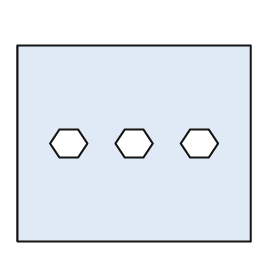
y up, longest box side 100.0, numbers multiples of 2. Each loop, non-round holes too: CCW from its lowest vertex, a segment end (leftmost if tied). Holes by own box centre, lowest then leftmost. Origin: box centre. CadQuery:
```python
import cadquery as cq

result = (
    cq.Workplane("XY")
    .moveTo(-50.0, -42.0)
    .lineTo(50.0, -42.0)
    .lineTo(50.0, 42.0)
    .lineTo(-50.0, 42.0)
    .close()
    .moveTo(-32.0, -6.0)
    .lineTo(-24.0, -6.0)
    .lineTo(-20.0, 0.0)
    .lineTo(-24.0, 6.0)
    .lineTo(-32.0, 6.0)
    .lineTo(-36.0, 0.0)
    .close()
    .moveTo(-4.0, -6.0)
    .lineTo(4.0, -6.0)
    .lineTo(8.0, 0.0)
    .lineTo(4.0, 6.0)
    .lineTo(-4.0, 6.0)
    .lineTo(-8.0, 0.0)
    .close()
    .moveTo(24.0, -6.0)
    .lineTo(32.0, -6.0)
    .lineTo(36.0, 0.0)
    .lineTo(32.0, 6.0)
    .lineTo(24.0, 6.0)
    .lineTo(20.0, 0.0)
    .close()
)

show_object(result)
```